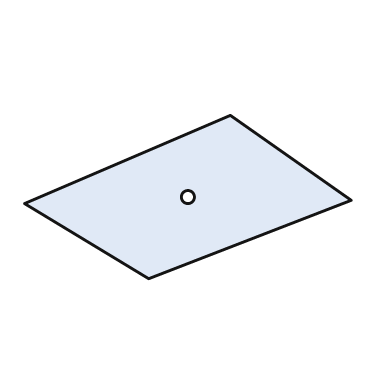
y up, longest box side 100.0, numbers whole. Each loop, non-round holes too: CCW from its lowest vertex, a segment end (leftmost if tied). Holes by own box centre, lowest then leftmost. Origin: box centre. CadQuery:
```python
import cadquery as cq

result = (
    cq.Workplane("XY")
    .moveTo(-12.0, -25.0)
    .lineTo(50.0, -1.0)
    .lineTo(13.0, 25.0)
    .lineTo(-50.0, -2.0)
    .close()
    .moveTo(0.0, 0.0)
    .circle(2.0)
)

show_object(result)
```